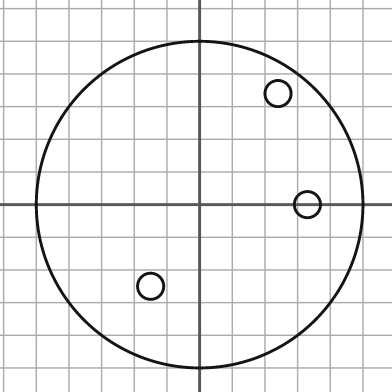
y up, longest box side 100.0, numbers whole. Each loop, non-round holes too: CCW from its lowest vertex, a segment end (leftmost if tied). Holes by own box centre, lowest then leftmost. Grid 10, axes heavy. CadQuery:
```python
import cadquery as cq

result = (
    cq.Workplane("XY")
    .moveTo(0.0, 0.0)
    .circle(50.0)
    .moveTo(-15.0, -25.0)
    .circle(4.0)
    .moveTo(33.0, 0.0)
    .circle(4.0)
    .moveTo(24.0, 34.0)
    .circle(4.0)
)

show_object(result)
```